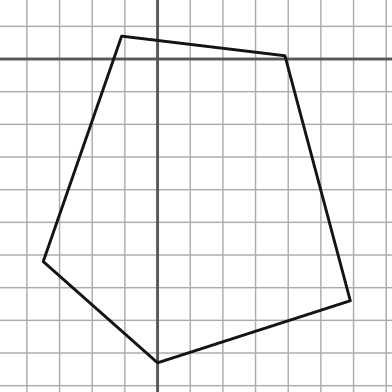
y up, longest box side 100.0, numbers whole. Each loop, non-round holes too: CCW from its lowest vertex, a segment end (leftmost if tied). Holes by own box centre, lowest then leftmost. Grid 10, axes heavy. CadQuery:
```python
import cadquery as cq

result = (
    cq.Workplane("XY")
    .moveTo(0.0, -93.0)
    .lineTo(59.0, -74.0)
    .lineTo(39.0, 1.0)
    .lineTo(-11.0, 7.0)
    .lineTo(-35.0, -62.0)
    .close()
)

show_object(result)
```